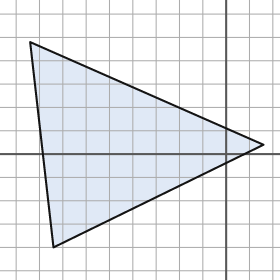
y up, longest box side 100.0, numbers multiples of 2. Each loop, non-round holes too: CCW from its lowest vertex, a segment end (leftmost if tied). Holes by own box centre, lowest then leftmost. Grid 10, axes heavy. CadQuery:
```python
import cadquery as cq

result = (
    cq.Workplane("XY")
    .moveTo(-74.0, -40.0)
    .lineTo(16.0, 4.0)
    .lineTo(-84.0, 48.0)
    .close()
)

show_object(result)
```